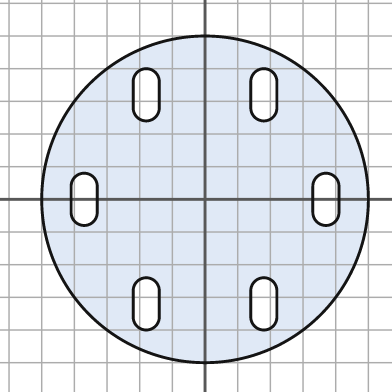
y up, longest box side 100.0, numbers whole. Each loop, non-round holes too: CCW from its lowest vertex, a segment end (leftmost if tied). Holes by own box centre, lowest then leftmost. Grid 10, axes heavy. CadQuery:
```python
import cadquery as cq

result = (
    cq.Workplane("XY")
    .moveTo(0.0, 0.0)
    .circle(50.0)
    .moveTo(-22.0, -36.0)
    .threePointArc((-18.0, -40.0), (-14.0, -36.0))
    .lineTo(-14.0, -28.0)
    .threePointArc((-18.0, -24.0), (-22.0, -28.0))
    .close()
    .moveTo(14.0, -36.0)
    .threePointArc((18.0, -40.0), (22.0, -36.0))
    .lineTo(22.0, -28.0)
    .threePointArc((18.0, -24.0), (14.0, -28.0))
    .close()
    .moveTo(-41.0, -4.0)
    .threePointArc((-37.0, -8.0), (-33.0, -4.0))
    .lineTo(-33.0, 4.0)
    .threePointArc((-37.0, 8.0), (-41.0, 4.0))
    .close()
    .moveTo(33.0, -4.0)
    .threePointArc((37.0, -8.0), (41.0, -4.0))
    .lineTo(41.0, 4.0)
    .threePointArc((37.0, 8.0), (33.0, 4.0))
    .close()
    .moveTo(-22.0, 28.0)
    .threePointArc((-18.0, 24.0), (-14.0, 28.0))
    .lineTo(-14.0, 36.0)
    .threePointArc((-18.0, 40.0), (-22.0, 36.0))
    .close()
    .moveTo(14.0, 28.0)
    .threePointArc((18.0, 24.0), (22.0, 28.0))
    .lineTo(22.0, 36.0)
    .threePointArc((18.0, 40.0), (14.0, 36.0))
    .close()
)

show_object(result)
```